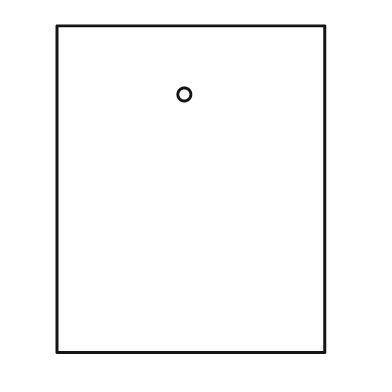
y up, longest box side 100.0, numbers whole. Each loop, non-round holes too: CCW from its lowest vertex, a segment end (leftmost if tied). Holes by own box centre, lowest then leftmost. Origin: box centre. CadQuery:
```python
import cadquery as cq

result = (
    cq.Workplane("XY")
    .moveTo(-41.0, -50.0)
    .lineTo(41.0, -50.0)
    .lineTo(41.0, 50.0)
    .lineTo(-41.0, 50.0)
    .close()
    .moveTo(-2.0, 29.0)
    .circle(2.0)
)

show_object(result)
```